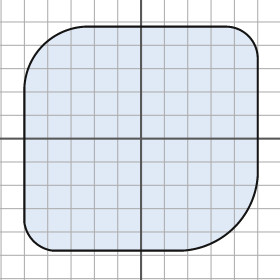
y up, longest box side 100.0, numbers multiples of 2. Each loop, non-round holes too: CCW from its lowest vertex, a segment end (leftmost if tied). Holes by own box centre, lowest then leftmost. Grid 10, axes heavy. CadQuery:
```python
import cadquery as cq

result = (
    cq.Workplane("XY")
    .moveTo(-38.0, -48.0)
    .lineTo(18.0, -48.0)
    .threePointArc((40.0, -38.0), (50.0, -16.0))
    .lineTo(50.0, 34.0)
    .threePointArc((46.0, 44.0), (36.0, 48.0))
    .lineTo(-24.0, 48.0)
    .threePointArc((-42.0, 40.0), (-50.0, 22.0))
    .lineTo(-50.0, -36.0)
    .threePointArc((-46.0, -44.0), (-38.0, -48.0))
    .close()
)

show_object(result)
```